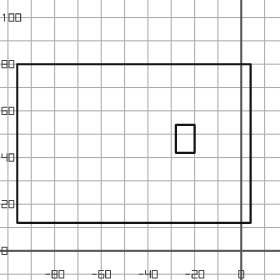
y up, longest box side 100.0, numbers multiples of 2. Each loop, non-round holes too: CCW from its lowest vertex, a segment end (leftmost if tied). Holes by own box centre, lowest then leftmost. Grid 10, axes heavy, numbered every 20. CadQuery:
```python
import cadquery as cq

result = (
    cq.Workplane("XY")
    .moveTo(-96.0, 12.0)
    .lineTo(4.0, 12.0)
    .lineTo(4.0, 80.0)
    .lineTo(-96.0, 80.0)
    .close()
    .moveTo(-28.0, 42.0)
    .lineTo(-20.0, 42.0)
    .lineTo(-20.0, 54.0)
    .lineTo(-28.0, 54.0)
    .close()
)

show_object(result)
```